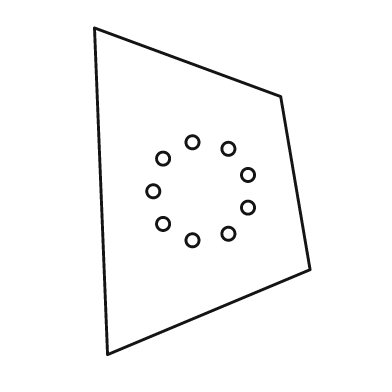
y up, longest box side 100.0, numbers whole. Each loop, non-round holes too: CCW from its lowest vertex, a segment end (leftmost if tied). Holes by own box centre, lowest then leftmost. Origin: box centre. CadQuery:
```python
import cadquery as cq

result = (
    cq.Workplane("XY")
    .moveTo(-29.0, -50.0)
    .lineTo(33.0, -24.0)
    .lineTo(24.0, 29.0)
    .lineTo(-33.0, 50.0)
    .close()
    .moveTo(-3.0, -15.0)
    .circle(2.0)
    .moveTo(8.0, -13.0)
    .circle(2.0)
    .moveTo(-12.0, -10.0)
    .circle(2.0)
    .moveTo(14.0, -5.0)
    .circle(2.0)
    .moveTo(-15.0, 0.0)
    .circle(2.0)
    .moveTo(14.0, 5.0)
    .circle(2.0)
    .moveTo(-12.0, 10.0)
    .circle(2.0)
    .moveTo(8.0, 13.0)
    .circle(2.0)
    .moveTo(-3.0, 15.0)
    .circle(2.0)
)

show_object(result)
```